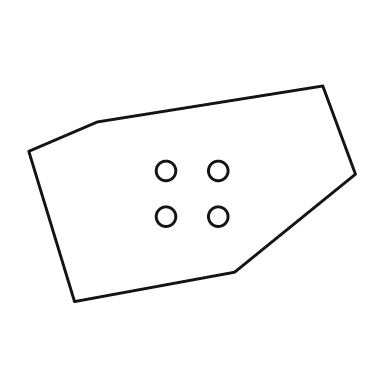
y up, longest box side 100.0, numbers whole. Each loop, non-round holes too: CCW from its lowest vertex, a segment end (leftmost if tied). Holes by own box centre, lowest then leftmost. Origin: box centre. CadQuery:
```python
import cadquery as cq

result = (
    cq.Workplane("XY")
    .moveTo(-36.0, -33.0)
    .lineTo(13.0, -24.0)
    .lineTo(50.0, 6.0)
    .lineTo(40.0, 33.0)
    .lineTo(-29.0, 22.0)
    .lineTo(-50.0, 13.0)
    .close()
    .moveTo(-8.0, -7.0)
    .circle(3.0)
    .moveTo(8.0, -7.0)
    .circle(3.0)
    .moveTo(-8.0, 7.0)
    .circle(3.0)
    .moveTo(8.0, 7.0)
    .circle(3.0)
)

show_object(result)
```